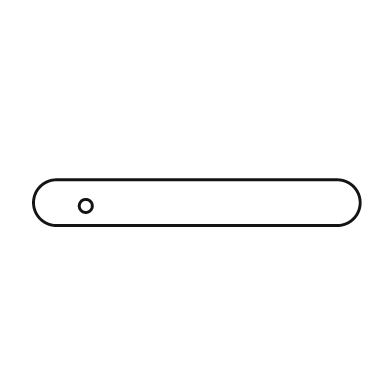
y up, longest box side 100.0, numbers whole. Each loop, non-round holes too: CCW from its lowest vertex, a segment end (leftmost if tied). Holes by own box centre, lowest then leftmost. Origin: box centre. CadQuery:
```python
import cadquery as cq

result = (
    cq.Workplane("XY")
    .moveTo(-43.0, -7.0)
    .lineTo(43.0, -7.0)
    .threePointArc((50.0, 0.0), (43.0, 7.0))
    .lineTo(-43.0, 7.0)
    .threePointArc((-50.0, 0.0), (-43.0, -7.0))
    .close()
    .moveTo(-34.0, -1.0)
    .circle(2.0)
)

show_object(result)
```